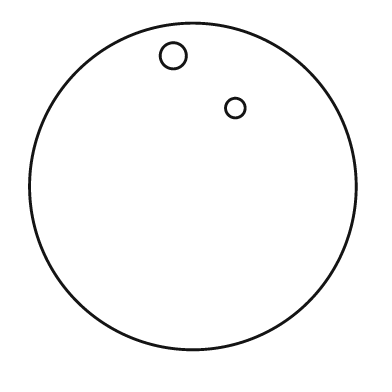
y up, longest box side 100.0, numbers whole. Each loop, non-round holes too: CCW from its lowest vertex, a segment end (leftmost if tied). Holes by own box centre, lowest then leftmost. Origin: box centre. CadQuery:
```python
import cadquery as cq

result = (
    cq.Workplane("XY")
    .moveTo(0.0, 0.0)
    .circle(50.0)
    .moveTo(13.0, 24.0)
    .circle(3.0)
    .moveTo(-6.0, 40.0)
    .circle(4.0)
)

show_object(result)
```